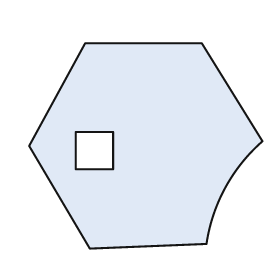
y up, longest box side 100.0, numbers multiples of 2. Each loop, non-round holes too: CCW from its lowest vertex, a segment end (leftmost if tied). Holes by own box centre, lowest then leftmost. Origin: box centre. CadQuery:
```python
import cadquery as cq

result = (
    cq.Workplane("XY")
    .moveTo(-24.0, -44.0)
    .lineTo(26.0, -42.0)
    .threePointArc((34.0, -18.0), (50.0, 2.0))
    .lineTo(24.0, 44.0)
    .lineTo(-26.0, 44.0)
    .lineTo(-50.0, 0.0)
    .close()
    .moveTo(-30.0, -10.0)
    .lineTo(-14.0, -10.0)
    .lineTo(-14.0, 6.0)
    .lineTo(-30.0, 6.0)
    .close()
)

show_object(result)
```